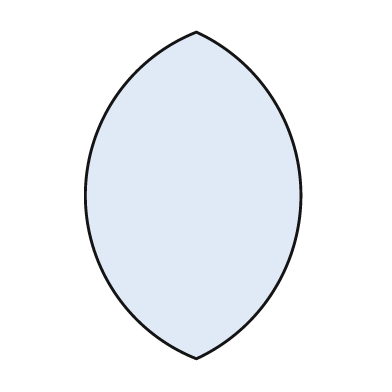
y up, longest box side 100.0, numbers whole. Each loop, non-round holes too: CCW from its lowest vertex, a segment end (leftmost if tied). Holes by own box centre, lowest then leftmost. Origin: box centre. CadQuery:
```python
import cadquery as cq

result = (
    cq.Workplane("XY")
    .moveTo(1.0, -50.0)
    .threePointArc((33.0, 0.0), (1.0, 50.0))
    .threePointArc((-33.0, 0.0), (1.0, -50.0))
    .close()
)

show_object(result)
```